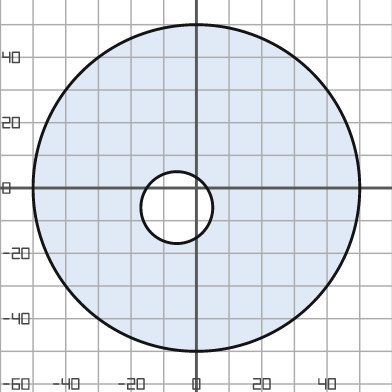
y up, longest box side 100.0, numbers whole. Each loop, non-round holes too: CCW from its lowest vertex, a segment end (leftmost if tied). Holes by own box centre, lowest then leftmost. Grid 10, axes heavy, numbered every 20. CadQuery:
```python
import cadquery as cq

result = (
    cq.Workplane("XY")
    .moveTo(0.0, 0.0)
    .circle(50.0)
    .moveTo(-6.0, -6.0)
    .circle(11.0)
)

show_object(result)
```